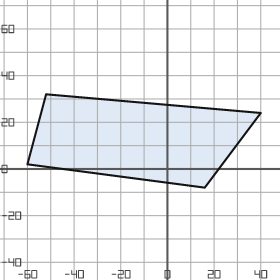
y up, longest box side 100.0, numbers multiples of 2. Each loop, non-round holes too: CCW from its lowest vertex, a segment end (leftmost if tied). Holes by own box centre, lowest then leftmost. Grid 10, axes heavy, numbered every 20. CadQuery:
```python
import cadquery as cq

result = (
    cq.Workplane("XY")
    .moveTo(16.0, -8.0)
    .lineTo(40.0, 24.0)
    .lineTo(-52.0, 32.0)
    .lineTo(-60.0, 2.0)
    .close()
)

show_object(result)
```